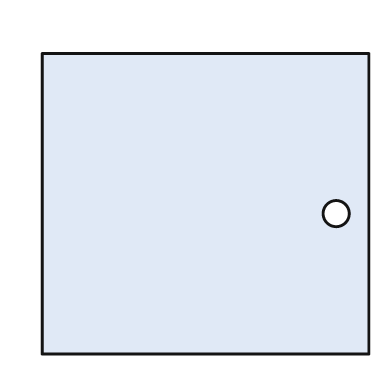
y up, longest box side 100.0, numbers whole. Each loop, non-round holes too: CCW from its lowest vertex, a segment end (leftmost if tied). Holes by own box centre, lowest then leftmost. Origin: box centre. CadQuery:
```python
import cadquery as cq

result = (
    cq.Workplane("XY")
    .moveTo(-50.0, -46.0)
    .lineTo(50.0, -46.0)
    .lineTo(50.0, 46.0)
    .lineTo(-50.0, 46.0)
    .close()
    .moveTo(40.0, -3.0)
    .circle(4.0)
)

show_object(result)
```